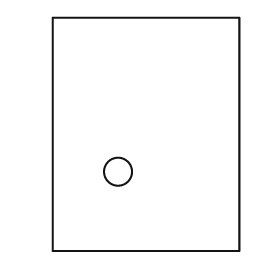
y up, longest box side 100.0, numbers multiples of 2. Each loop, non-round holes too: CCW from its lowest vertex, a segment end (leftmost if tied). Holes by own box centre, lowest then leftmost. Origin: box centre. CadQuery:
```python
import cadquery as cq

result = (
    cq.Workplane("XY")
    .moveTo(-40.0, -50.0)
    .lineTo(40.0, -50.0)
    .lineTo(40.0, 50.0)
    .lineTo(-40.0, 50.0)
    .close()
    .moveTo(-12.0, -16.0)
    .circle(6.0)
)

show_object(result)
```